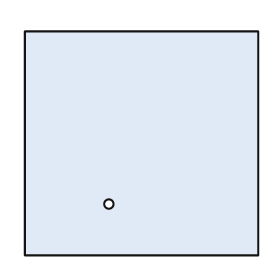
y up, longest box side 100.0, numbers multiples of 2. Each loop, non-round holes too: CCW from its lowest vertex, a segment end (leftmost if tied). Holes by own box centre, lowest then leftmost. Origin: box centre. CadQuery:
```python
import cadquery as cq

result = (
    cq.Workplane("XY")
    .moveTo(-50.0, -48.0)
    .lineTo(50.0, -48.0)
    .lineTo(50.0, 48.0)
    .lineTo(-50.0, 48.0)
    .close()
    .moveTo(-14.0, -26.0)
    .circle(2.0)
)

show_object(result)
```